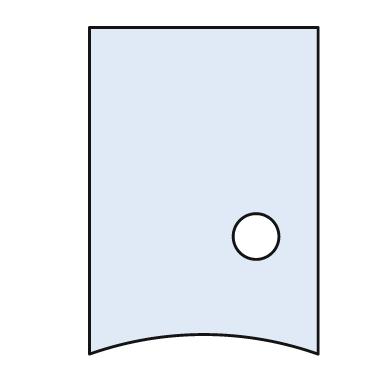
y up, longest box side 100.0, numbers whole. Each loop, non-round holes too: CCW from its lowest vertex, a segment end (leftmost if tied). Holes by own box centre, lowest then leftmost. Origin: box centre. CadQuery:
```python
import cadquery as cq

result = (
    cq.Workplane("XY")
    .moveTo(-35.0, -50.0)
    .threePointArc((0.0, -44.0), (35.0, -50.0))
    .lineTo(35.0, 50.0)
    .lineTo(-35.0, 50.0)
    .close()
    .moveTo(16.0, -14.0)
    .circle(7.0)
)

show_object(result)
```